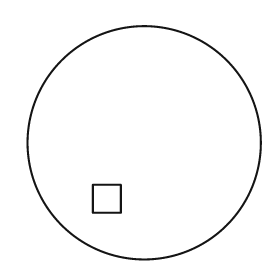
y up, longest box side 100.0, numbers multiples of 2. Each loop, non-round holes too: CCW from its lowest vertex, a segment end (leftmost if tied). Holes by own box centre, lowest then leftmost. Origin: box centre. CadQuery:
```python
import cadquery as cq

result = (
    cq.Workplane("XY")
    .moveTo(0.0, 0.0)
    .circle(50.0)
    .moveTo(-22.0, -30.0)
    .lineTo(-10.0, -30.0)
    .lineTo(-10.0, -18.0)
    .lineTo(-22.0, -18.0)
    .close()
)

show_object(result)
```